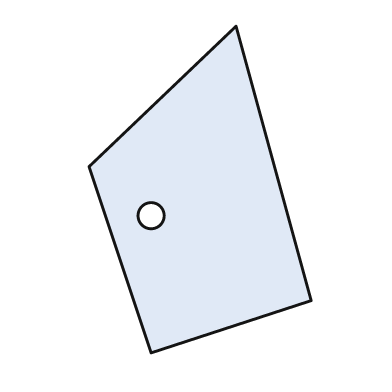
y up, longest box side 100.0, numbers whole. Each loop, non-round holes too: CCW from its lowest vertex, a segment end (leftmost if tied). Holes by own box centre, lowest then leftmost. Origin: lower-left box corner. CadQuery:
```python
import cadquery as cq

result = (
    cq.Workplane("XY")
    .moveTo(19.0, 0.0)
    .lineTo(68.0, 16.0)
    .lineTo(45.0, 100.0)
    .lineTo(0.0, 57.0)
    .close()
    .moveTo(19.0, 42.0)
    .circle(4.0)
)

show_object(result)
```